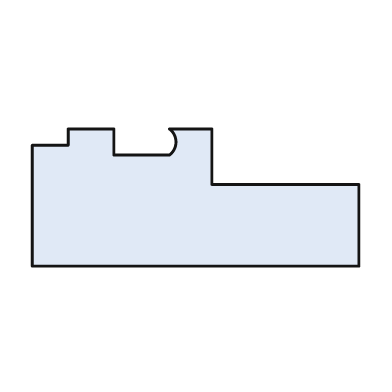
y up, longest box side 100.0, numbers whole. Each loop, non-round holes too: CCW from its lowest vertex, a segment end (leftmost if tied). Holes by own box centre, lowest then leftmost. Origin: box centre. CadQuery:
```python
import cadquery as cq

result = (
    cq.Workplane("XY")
    .moveTo(-50.0, -21.0)
    .lineTo(50.0, -21.0)
    .lineTo(50.0, 4.0)
    .lineTo(5.0, 4.0)
    .lineTo(5.0, 21.0)
    .lineTo(-8.0, 21.0)
    .threePointArc((-6.0, 17.0), (-8.0, 13.0))
    .lineTo(-25.0, 13.0)
    .lineTo(-25.0, 21.0)
    .lineTo(-39.0, 21.0)
    .lineTo(-39.0, 16.0)
    .lineTo(-50.0, 16.0)
    .close()
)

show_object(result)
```